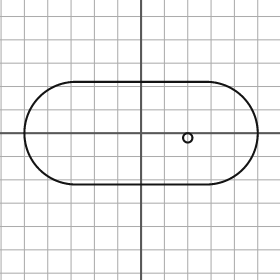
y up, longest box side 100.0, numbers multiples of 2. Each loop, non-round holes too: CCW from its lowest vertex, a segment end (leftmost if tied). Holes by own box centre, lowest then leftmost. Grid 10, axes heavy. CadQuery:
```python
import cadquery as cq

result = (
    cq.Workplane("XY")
    .moveTo(-28.0, -22.0)
    .lineTo(28.0, -22.0)
    .threePointArc((50.0, 0.0), (28.0, 22.0))
    .lineTo(-28.0, 22.0)
    .threePointArc((-50.0, 0.0), (-28.0, -22.0))
    .close()
    .moveTo(20.0, -2.0)
    .circle(2.0)
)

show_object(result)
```